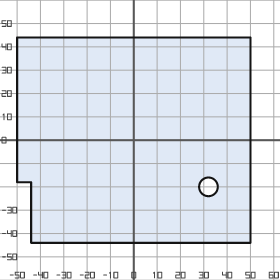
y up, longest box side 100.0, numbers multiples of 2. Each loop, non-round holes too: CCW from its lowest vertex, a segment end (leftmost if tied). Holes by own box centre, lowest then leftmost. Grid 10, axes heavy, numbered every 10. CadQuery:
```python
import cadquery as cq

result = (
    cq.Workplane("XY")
    .moveTo(-44.0, -44.0)
    .lineTo(50.0, -44.0)
    .lineTo(50.0, 44.0)
    .lineTo(-50.0, 44.0)
    .lineTo(-50.0, -18.0)
    .lineTo(-44.0, -18.0)
    .close()
    .moveTo(32.0, -20.0)
    .circle(4.0)
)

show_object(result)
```